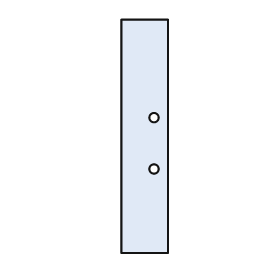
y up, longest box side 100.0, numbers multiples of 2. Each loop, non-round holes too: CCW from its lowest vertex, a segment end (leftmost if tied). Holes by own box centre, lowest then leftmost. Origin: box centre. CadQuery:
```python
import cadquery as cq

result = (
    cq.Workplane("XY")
    .moveTo(-10.0, -50.0)
    .lineTo(10.0, -50.0)
    .lineTo(10.0, 50.0)
    .lineTo(-10.0, 50.0)
    .close()
    .moveTo(4.0, -14.0)
    .circle(2.0)
    .moveTo(4.0, 8.0)
    .circle(2.0)
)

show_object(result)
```